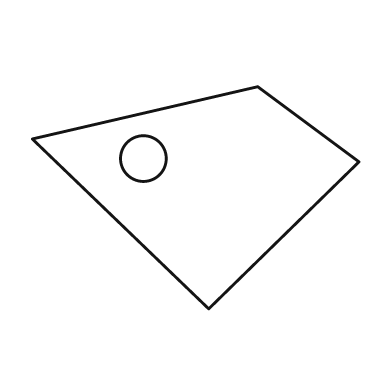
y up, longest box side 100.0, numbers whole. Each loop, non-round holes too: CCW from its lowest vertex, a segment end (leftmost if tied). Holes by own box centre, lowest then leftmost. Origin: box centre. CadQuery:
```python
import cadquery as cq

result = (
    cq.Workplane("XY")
    .moveTo(4.0, -34.0)
    .lineTo(50.0, 11.0)
    .lineTo(19.0, 34.0)
    .lineTo(-50.0, 18.0)
    .close()
    .moveTo(-16.0, 12.0)
    .circle(7.0)
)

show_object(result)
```